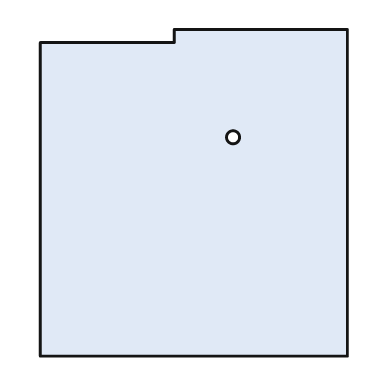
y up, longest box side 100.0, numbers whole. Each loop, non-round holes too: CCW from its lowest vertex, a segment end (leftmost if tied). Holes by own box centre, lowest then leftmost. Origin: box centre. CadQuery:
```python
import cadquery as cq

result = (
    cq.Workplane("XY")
    .moveTo(-47.0, -50.0)
    .lineTo(47.0, -50.0)
    .lineTo(47.0, 50.0)
    .lineTo(-6.0, 50.0)
    .lineTo(-6.0, 46.0)
    .lineTo(-47.0, 46.0)
    .close()
    .moveTo(12.0, 17.0)
    .circle(2.0)
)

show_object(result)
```